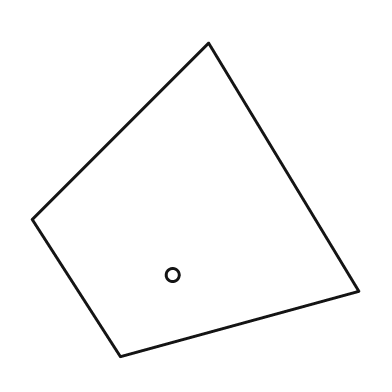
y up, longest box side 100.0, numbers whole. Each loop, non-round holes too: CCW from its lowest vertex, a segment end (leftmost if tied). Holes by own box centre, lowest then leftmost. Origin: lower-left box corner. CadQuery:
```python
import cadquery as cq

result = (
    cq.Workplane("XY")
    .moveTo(27.0, 0.0)
    .lineTo(100.0, 20.0)
    .lineTo(54.0, 96.0)
    .lineTo(0.0, 42.0)
    .close()
    .moveTo(43.0, 25.0)
    .circle(2.0)
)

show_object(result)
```